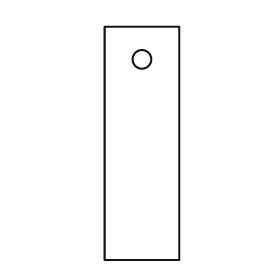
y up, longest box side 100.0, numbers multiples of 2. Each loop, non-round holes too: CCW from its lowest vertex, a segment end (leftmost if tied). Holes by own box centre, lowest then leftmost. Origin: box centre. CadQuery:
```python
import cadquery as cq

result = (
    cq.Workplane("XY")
    .moveTo(-16.0, -50.0)
    .lineTo(16.0, -50.0)
    .lineTo(16.0, 50.0)
    .lineTo(-16.0, 50.0)
    .close()
    .moveTo(0.0, 36.0)
    .circle(4.0)
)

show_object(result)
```